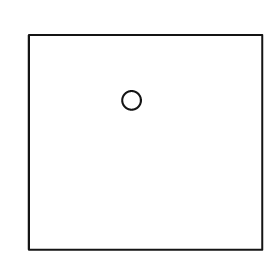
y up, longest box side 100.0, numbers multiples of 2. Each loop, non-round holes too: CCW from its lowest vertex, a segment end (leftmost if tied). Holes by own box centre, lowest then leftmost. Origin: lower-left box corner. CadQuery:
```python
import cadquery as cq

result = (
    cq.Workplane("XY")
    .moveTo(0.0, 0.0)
    .lineTo(100.0, 0.0)
    .lineTo(100.0, 92.0)
    .lineTo(0.0, 92.0)
    .close()
    .moveTo(44.0, 64.0)
    .circle(4.0)
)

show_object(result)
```